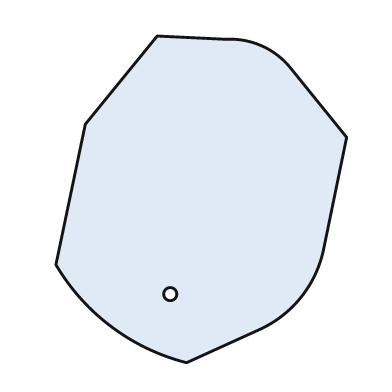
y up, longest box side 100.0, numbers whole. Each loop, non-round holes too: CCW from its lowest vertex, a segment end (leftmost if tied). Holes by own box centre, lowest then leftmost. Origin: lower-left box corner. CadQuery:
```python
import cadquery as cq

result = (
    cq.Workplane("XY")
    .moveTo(40.0, 0.0)
    .lineTo(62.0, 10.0)
    .threePointArc((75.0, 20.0), (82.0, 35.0))
    .lineTo(89.0, 69.0)
    .lineTo(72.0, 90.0)
    .threePointArc((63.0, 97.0), (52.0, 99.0))
    .lineTo(31.0, 100.0)
    .lineTo(9.0, 73.0)
    .lineTo(0.0, 30.0)
    .threePointArc((17.0, 11.0), (40.0, 0.0))
    .close()
    .moveTo(35.0, 21.0)
    .circle(2.0)
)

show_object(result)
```